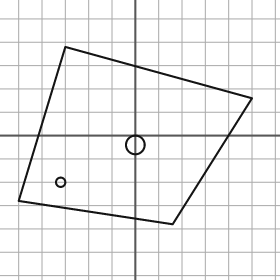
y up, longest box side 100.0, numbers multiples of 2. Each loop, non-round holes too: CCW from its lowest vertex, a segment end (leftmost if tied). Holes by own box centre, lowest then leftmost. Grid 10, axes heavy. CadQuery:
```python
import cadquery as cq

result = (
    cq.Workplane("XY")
    .moveTo(16.0, -38.0)
    .lineTo(50.0, 16.0)
    .lineTo(-30.0, 38.0)
    .lineTo(-50.0, -28.0)
    .close()
    .moveTo(-32.0, -20.0)
    .circle(2.0)
    .moveTo(0.0, -4.0)
    .circle(4.0)
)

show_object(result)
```